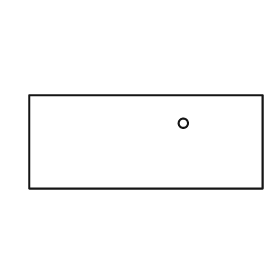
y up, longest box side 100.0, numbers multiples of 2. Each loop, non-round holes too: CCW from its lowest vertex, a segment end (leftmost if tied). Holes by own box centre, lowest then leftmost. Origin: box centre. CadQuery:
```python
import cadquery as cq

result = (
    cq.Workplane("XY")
    .moveTo(-50.0, -20.0)
    .lineTo(50.0, -20.0)
    .lineTo(50.0, 20.0)
    .lineTo(-50.0, 20.0)
    .close()
    .moveTo(16.0, 8.0)
    .circle(2.0)
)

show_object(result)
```